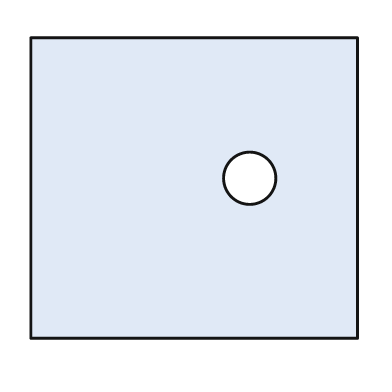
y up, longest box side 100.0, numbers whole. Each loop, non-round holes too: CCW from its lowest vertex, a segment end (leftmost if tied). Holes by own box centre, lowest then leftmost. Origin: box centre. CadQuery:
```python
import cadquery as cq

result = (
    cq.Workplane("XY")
    .moveTo(-50.0, -46.0)
    .lineTo(50.0, -46.0)
    .lineTo(50.0, 46.0)
    .lineTo(-50.0, 46.0)
    .close()
    .moveTo(17.0, 3.0)
    .circle(8.0)
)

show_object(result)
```